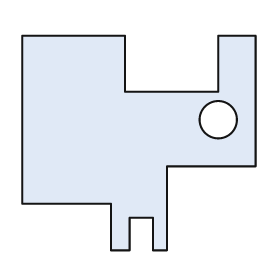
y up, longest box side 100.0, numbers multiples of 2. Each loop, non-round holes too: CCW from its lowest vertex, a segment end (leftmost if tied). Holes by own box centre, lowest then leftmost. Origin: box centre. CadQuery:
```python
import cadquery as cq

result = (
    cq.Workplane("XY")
    .moveTo(-12.0, -46.0)
    .lineTo(-4.0, -46.0)
    .lineTo(-4.0, -32.0)
    .lineTo(6.0, -32.0)
    .lineTo(6.0, -46.0)
    .lineTo(12.0, -46.0)
    .lineTo(12.0, -10.0)
    .lineTo(50.0, -10.0)
    .lineTo(50.0, 46.0)
    .lineTo(34.0, 46.0)
    .lineTo(34.0, 22.0)
    .lineTo(-6.0, 22.0)
    .lineTo(-6.0, 46.0)
    .lineTo(-50.0, 46.0)
    .lineTo(-50.0, -26.0)
    .lineTo(-12.0, -26.0)
    .close()
    .moveTo(34.0, 10.0)
    .circle(8.0)
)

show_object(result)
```